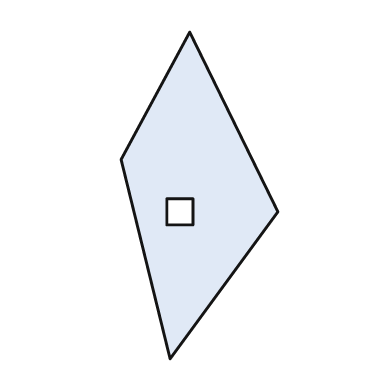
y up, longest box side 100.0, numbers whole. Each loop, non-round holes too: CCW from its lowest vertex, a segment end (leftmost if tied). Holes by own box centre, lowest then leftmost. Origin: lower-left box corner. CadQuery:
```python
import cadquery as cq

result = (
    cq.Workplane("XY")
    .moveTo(15.0, 0.0)
    .lineTo(48.0, 45.0)
    .lineTo(21.0, 100.0)
    .lineTo(0.0, 61.0)
    .close()
    .moveTo(14.0, 41.0)
    .lineTo(22.0, 41.0)
    .lineTo(22.0, 49.0)
    .lineTo(14.0, 49.0)
    .close()
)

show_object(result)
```